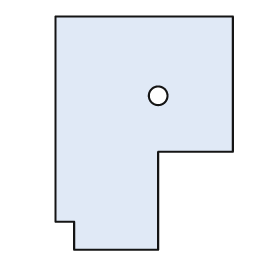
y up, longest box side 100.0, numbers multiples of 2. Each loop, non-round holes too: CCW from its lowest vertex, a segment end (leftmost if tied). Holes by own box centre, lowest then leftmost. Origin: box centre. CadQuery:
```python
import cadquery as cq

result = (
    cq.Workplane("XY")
    .moveTo(-30.0, -50.0)
    .lineTo(6.0, -50.0)
    .lineTo(6.0, -8.0)
    .lineTo(38.0, -8.0)
    .lineTo(38.0, 50.0)
    .lineTo(-38.0, 50.0)
    .lineTo(-38.0, -38.0)
    .lineTo(-30.0, -38.0)
    .close()
    .moveTo(6.0, 16.0)
    .circle(4.0)
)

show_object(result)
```